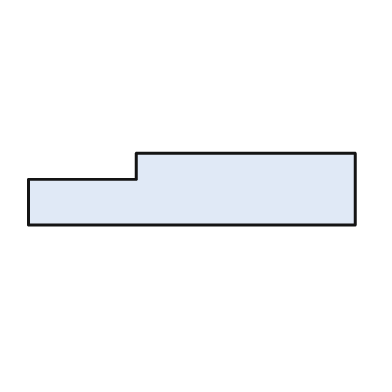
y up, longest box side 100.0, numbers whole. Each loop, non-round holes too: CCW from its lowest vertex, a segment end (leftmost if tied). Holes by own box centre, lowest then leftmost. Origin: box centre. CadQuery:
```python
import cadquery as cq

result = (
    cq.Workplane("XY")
    .moveTo(-50.0, -11.0)
    .lineTo(50.0, -11.0)
    .lineTo(50.0, 11.0)
    .lineTo(-17.0, 11.0)
    .lineTo(-17.0, 3.0)
    .lineTo(-50.0, 3.0)
    .close()
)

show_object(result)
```